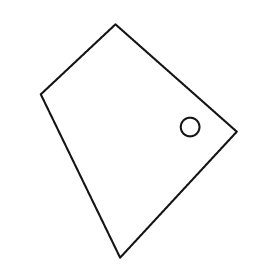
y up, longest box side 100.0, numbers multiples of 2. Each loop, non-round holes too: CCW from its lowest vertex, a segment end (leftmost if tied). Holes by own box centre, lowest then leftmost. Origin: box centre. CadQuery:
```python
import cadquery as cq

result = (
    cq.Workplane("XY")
    .moveTo(-8.0, -50.0)
    .lineTo(42.0, 4.0)
    .lineTo(-10.0, 50.0)
    .lineTo(-42.0, 20.0)
    .close()
    .moveTo(22.0, 6.0)
    .circle(4.0)
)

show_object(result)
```